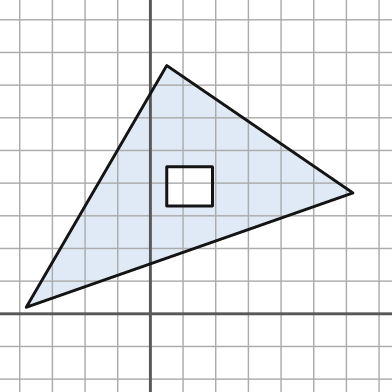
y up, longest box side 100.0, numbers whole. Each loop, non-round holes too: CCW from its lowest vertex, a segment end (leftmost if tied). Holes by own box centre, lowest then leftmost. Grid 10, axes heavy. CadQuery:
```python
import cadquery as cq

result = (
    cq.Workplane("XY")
    .moveTo(-38.0, 2.0)
    .lineTo(62.0, 37.0)
    .lineTo(5.0, 76.0)
    .close()
    .moveTo(5.0, 33.0)
    .lineTo(19.0, 33.0)
    .lineTo(19.0, 45.0)
    .lineTo(5.0, 45.0)
    .close()
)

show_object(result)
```